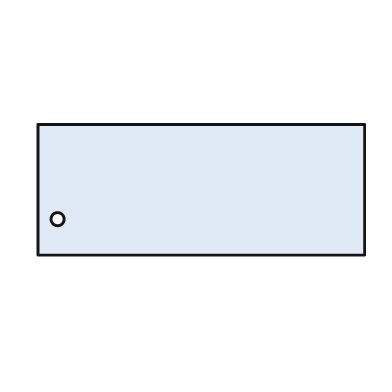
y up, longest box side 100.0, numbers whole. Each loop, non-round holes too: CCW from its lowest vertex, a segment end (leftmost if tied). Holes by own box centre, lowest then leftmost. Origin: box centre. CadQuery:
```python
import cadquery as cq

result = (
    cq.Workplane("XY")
    .moveTo(-50.0, -20.0)
    .lineTo(50.0, -20.0)
    .lineTo(50.0, 20.0)
    .lineTo(-50.0, 20.0)
    .close()
    .moveTo(-44.0, -9.0)
    .circle(2.0)
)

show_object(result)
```